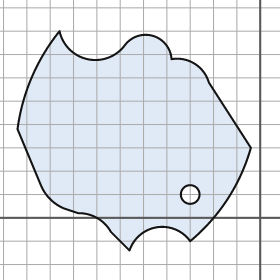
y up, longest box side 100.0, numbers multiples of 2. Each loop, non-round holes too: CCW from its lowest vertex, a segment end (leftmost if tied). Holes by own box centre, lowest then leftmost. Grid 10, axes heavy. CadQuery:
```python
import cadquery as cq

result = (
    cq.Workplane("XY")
    .moveTo(-56.0, -14.0)
    .threePointArc((-44.0, -4.0), (-30.0, -10.0))
    .threePointArc((-14.0, 8.0), (-4.0, 30.0))
    .lineTo(-22.0, 58.0)
    .threePointArc((-28.0, 66.0), (-38.0, 68.0))
    .threePointArc((-46.0, 78.0), (-58.0, 74.0))
    .threePointArc((-74.0, 68.0), (-86.0, 80.0))
    .threePointArc((-98.0, 60.0), (-104.0, 38.0))
    .lineTo(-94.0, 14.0)
    .threePointArc((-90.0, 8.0), (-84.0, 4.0))
    .lineTo(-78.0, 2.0)
    .threePointArc((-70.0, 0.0), (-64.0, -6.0))
    .close()
    .moveTo(-30.0, 10.0)
    .circle(4.0)
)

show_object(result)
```